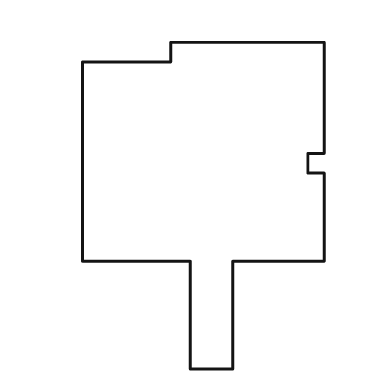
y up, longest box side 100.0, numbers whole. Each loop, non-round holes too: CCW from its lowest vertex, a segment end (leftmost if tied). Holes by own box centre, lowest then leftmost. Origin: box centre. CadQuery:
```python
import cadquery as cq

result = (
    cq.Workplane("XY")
    .moveTo(-4.0, -50.0)
    .lineTo(9.0, -50.0)
    .lineTo(9.0, -17.0)
    .lineTo(37.0, -17.0)
    .lineTo(37.0, 10.0)
    .lineTo(32.0, 10.0)
    .lineTo(32.0, 16.0)
    .lineTo(37.0, 16.0)
    .lineTo(37.0, 50.0)
    .lineTo(-10.0, 50.0)
    .lineTo(-10.0, 44.0)
    .lineTo(-37.0, 44.0)
    .lineTo(-37.0, -17.0)
    .lineTo(-4.0, -17.0)
    .close()
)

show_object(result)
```